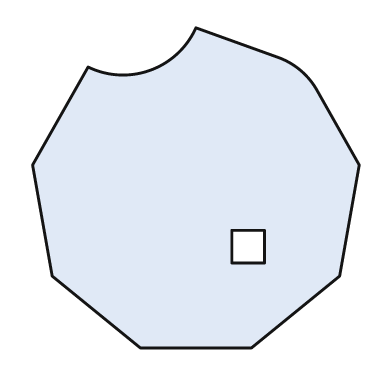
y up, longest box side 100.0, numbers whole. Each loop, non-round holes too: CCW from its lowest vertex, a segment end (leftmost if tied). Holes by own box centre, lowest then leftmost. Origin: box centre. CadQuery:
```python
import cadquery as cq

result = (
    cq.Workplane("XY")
    .moveTo(-17.0, -49.0)
    .lineTo(17.0, -49.0)
    .lineTo(44.0, -27.0)
    .lineTo(50.0, 7.0)
    .lineTo(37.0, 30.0)
    .threePointArc((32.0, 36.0), (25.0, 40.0))
    .lineTo(0.0, 49.0)
    .threePointArc((-14.0, 36.0), (-33.0, 37.0))
    .lineTo(-50.0, 7.0)
    .lineTo(-44.0, -27.0)
    .close()
    .moveTo(11.0, -23.0)
    .lineTo(21.0, -23.0)
    .lineTo(21.0, -13.0)
    .lineTo(11.0, -13.0)
    .close()
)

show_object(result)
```